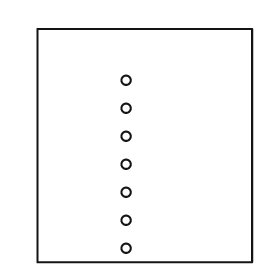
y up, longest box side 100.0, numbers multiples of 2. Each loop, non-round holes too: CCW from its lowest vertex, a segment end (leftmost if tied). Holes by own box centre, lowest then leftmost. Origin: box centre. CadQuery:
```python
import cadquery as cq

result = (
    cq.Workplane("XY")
    .moveTo(-46.0, -50.0)
    .lineTo(46.0, -50.0)
    .lineTo(46.0, 50.0)
    .lineTo(-46.0, 50.0)
    .close()
    .moveTo(-8.0, -44.0)
    .circle(2.0)
    .moveTo(-8.0, -32.0)
    .circle(2.0)
    .moveTo(-8.0, -20.0)
    .circle(2.0)
    .moveTo(-8.0, -8.0)
    .circle(2.0)
    .moveTo(-8.0, 4.0)
    .circle(2.0)
    .moveTo(-8.0, 16.0)
    .circle(2.0)
    .moveTo(-8.0, 28.0)
    .circle(2.0)
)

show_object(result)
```